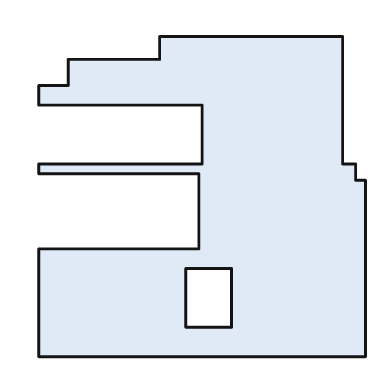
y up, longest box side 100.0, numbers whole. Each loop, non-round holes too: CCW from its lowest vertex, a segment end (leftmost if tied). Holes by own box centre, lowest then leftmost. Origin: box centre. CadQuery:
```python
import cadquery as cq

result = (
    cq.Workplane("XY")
    .moveTo(-50.0, -49.0)
    .lineTo(50.0, -49.0)
    .lineTo(50.0, 5.0)
    .lineTo(47.0, 5.0)
    .lineTo(47.0, 10.0)
    .lineTo(43.0, 10.0)
    .lineTo(43.0, 49.0)
    .lineTo(-13.0, 49.0)
    .lineTo(-13.0, 42.0)
    .lineTo(-41.0, 42.0)
    .lineTo(-41.0, 34.0)
    .lineTo(-50.0, 34.0)
    .lineTo(-50.0, 28.0)
    .lineTo(0.0, 28.0)
    .lineTo(0.0, 10.0)
    .lineTo(-50.0, 10.0)
    .lineTo(-50.0, 7.0)
    .lineTo(-1.0, 7.0)
    .lineTo(-1.0, -16.0)
    .lineTo(-50.0, -16.0)
    .close()
    .moveTo(-5.0, -40.0)
    .lineTo(9.0, -40.0)
    .lineTo(9.0, -22.0)
    .lineTo(-5.0, -22.0)
    .close()
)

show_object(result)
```